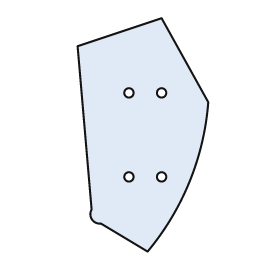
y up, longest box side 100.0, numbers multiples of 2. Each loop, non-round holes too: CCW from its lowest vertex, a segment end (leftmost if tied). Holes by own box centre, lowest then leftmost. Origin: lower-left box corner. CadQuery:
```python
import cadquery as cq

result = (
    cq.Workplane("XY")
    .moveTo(30.0, 0.0)
    .threePointArc((48.0, 30.0), (56.0, 64.0))
    .lineTo(36.0, 100.0)
    .lineTo(0.0, 88.0)
    .lineTo(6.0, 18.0)
    .threePointArc((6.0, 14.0), (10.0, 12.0))
    .close()
    .moveTo(22.0, 32.0)
    .circle(2.0)
    .moveTo(36.0, 32.0)
    .circle(2.0)
    .moveTo(22.0, 68.0)
    .circle(2.0)
    .moveTo(36.0, 68.0)
    .circle(2.0)
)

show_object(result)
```